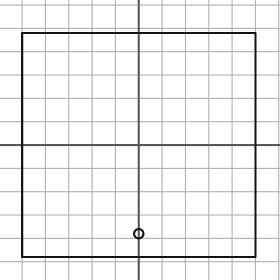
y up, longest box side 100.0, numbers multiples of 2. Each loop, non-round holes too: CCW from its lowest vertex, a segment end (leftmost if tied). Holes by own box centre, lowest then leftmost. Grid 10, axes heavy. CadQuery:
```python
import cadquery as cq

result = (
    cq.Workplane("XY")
    .moveTo(-50.0, -48.0)
    .lineTo(50.0, -48.0)
    .lineTo(50.0, 48.0)
    .lineTo(-50.0, 48.0)
    .close()
    .moveTo(0.0, -38.0)
    .circle(2.0)
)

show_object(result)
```